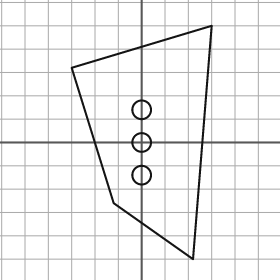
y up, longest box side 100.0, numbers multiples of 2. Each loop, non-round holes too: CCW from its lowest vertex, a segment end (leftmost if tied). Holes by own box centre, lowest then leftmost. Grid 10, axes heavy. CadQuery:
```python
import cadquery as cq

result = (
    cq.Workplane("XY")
    .moveTo(22.0, -50.0)
    .lineTo(30.0, 50.0)
    .lineTo(-30.0, 32.0)
    .lineTo(-12.0, -26.0)
    .close()
    .moveTo(0.0, -14.0)
    .circle(4.0)
    .moveTo(0.0, 0.0)
    .circle(4.0)
    .moveTo(0.0, 14.0)
    .circle(4.0)
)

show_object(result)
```